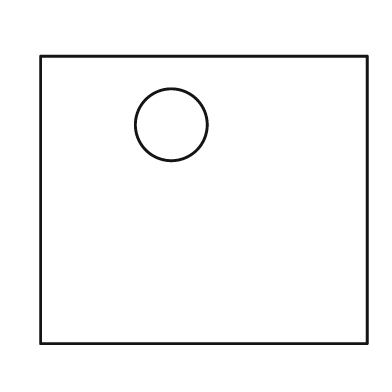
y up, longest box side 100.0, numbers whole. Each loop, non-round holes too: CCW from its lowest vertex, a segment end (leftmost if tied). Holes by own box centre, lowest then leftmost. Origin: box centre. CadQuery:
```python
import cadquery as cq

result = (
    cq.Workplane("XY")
    .moveTo(-50.0, -44.0)
    .lineTo(50.0, -44.0)
    .lineTo(50.0, 44.0)
    .lineTo(-50.0, 44.0)
    .close()
    .moveTo(-10.0, 23.0)
    .circle(11.0)
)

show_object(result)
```